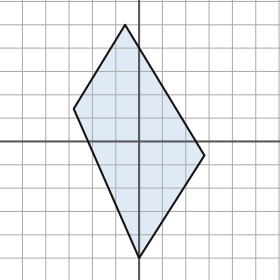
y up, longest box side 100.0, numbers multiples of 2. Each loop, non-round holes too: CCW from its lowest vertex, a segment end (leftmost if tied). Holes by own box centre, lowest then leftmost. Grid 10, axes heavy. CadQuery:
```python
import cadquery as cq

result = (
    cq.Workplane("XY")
    .moveTo(0.0, -50.0)
    .lineTo(28.0, -6.0)
    .lineTo(-6.0, 50.0)
    .lineTo(-28.0, 14.0)
    .close()
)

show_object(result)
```